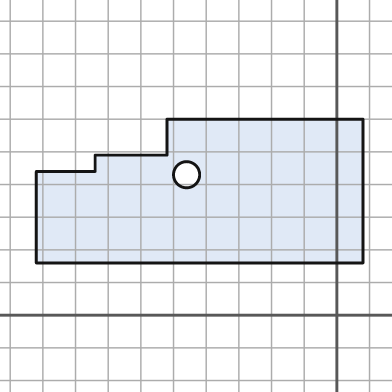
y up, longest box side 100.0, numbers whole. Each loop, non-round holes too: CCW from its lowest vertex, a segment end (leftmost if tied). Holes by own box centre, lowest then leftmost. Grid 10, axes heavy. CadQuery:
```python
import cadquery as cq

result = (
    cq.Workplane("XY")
    .moveTo(-92.0, 16.0)
    .lineTo(8.0, 16.0)
    .lineTo(8.0, 60.0)
    .lineTo(-52.0, 60.0)
    .lineTo(-52.0, 49.0)
    .lineTo(-74.0, 49.0)
    .lineTo(-74.0, 44.0)
    .lineTo(-92.0, 44.0)
    .close()
    .moveTo(-46.0, 43.0)
    .circle(4.0)
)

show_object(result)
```